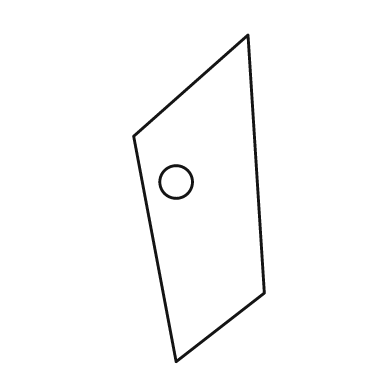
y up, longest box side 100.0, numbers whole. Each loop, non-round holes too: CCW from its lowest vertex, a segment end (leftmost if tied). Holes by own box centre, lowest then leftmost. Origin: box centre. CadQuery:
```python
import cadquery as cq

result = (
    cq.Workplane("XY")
    .moveTo(-7.0, -50.0)
    .lineTo(20.0, -29.0)
    .lineTo(15.0, 50.0)
    .lineTo(-20.0, 19.0)
    .close()
    .moveTo(-7.0, 5.0)
    .circle(5.0)
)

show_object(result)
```